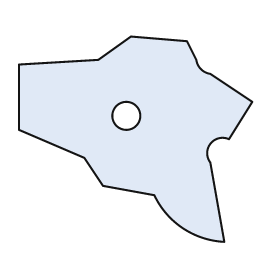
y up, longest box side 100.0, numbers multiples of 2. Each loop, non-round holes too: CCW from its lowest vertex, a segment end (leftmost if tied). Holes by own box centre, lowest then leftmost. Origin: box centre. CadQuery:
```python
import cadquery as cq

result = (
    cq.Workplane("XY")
    .moveTo(38.0, -44.0)
    .lineTo(32.0, -10.0)
    .threePointArc((32.0, -2.0), (40.0, 0.0))
    .lineTo(50.0, 16.0)
    .lineTo(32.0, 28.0)
    .threePointArc((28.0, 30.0), (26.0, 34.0))
    .lineTo(22.0, 42.0)
    .lineTo(-2.0, 44.0)
    .lineTo(-16.0, 34.0)
    .lineTo(-50.0, 32.0)
    .lineTo(-50.0, 4.0)
    .lineTo(-22.0, -8.0)
    .lineTo(-14.0, -20.0)
    .lineTo(8.0, -24.0)
    .threePointArc((20.0, -38.0), (38.0, -44.0))
    .close()
    .moveTo(-4.0, 10.0)
    .circle(6.0)
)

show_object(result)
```